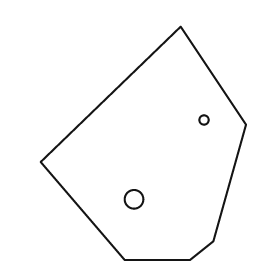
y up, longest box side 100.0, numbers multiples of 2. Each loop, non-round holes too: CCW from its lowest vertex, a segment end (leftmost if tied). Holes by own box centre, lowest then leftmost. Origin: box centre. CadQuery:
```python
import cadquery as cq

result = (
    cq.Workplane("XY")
    .moveTo(-8.0, -50.0)
    .lineTo(20.0, -50.0)
    .lineTo(30.0, -42.0)
    .lineTo(44.0, 8.0)
    .lineTo(16.0, 50.0)
    .lineTo(-44.0, -8.0)
    .close()
    .moveTo(-4.0, -24.0)
    .circle(4.0)
    .moveTo(26.0, 10.0)
    .circle(2.0)
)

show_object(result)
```